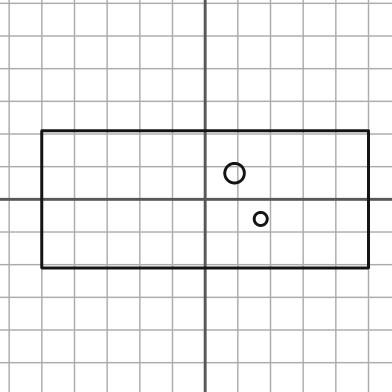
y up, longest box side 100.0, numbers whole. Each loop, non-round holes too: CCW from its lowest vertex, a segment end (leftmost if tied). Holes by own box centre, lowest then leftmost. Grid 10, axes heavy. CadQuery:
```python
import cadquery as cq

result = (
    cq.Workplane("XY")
    .moveTo(-50.0, -21.0)
    .lineTo(50.0, -21.0)
    .lineTo(50.0, 21.0)
    .lineTo(-50.0, 21.0)
    .close()
    .moveTo(17.0, -6.0)
    .circle(2.0)
    .moveTo(9.0, 8.0)
    .circle(3.0)
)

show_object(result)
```